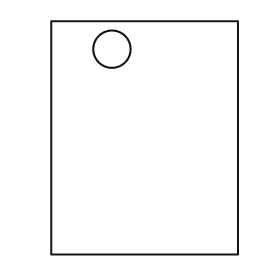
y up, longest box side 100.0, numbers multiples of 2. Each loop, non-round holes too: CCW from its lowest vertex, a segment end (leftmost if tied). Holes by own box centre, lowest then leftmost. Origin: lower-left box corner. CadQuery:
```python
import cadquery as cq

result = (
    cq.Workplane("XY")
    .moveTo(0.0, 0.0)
    .lineTo(80.0, 0.0)
    .lineTo(80.0, 100.0)
    .lineTo(0.0, 100.0)
    .close()
    .moveTo(26.0, 88.0)
    .circle(8.0)
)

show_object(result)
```